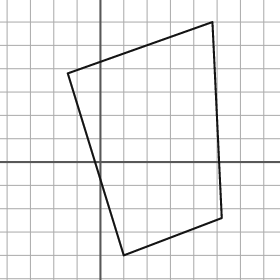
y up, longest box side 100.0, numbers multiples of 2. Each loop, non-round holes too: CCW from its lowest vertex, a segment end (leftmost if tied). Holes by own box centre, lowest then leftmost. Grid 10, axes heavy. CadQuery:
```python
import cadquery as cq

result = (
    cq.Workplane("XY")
    .moveTo(10.0, -40.0)
    .lineTo(52.0, -24.0)
    .lineTo(48.0, 60.0)
    .lineTo(-14.0, 38.0)
    .close()
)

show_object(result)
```